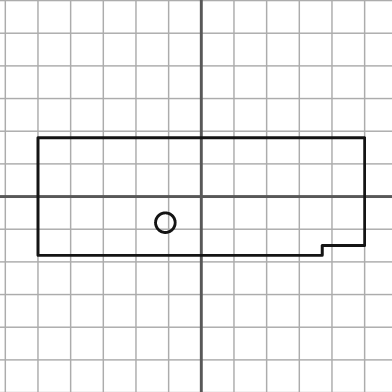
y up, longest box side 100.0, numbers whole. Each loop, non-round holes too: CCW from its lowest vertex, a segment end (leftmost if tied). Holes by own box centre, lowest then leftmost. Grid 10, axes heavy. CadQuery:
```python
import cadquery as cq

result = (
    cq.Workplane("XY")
    .moveTo(-50.0, -18.0)
    .lineTo(37.0, -18.0)
    .lineTo(37.0, -15.0)
    .lineTo(50.0, -15.0)
    .lineTo(50.0, 18.0)
    .lineTo(-50.0, 18.0)
    .close()
    .moveTo(-11.0, -8.0)
    .circle(3.0)
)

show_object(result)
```